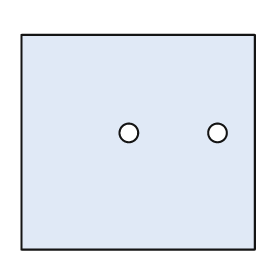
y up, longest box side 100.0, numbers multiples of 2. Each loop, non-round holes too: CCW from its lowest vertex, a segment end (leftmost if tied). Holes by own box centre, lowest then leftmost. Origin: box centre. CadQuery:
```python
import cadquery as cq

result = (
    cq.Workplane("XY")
    .moveTo(-50.0, -46.0)
    .lineTo(50.0, -46.0)
    .lineTo(50.0, 46.0)
    .lineTo(-50.0, 46.0)
    .close()
    .moveTo(-4.0, 4.0)
    .circle(4.0)
    .moveTo(34.0, 4.0)
    .circle(4.0)
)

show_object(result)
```